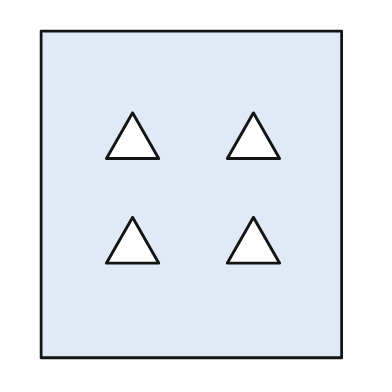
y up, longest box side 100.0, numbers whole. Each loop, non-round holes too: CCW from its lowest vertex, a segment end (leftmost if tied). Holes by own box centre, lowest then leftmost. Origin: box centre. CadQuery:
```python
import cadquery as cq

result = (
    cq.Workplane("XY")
    .moveTo(-46.0, -50.0)
    .lineTo(46.0, -50.0)
    .lineTo(46.0, 50.0)
    .lineTo(-46.0, 50.0)
    .close()
    .moveTo(-26.0, -21.0)
    .lineTo(-10.0, -21.0)
    .lineTo(-18.0, -7.0)
    .close()
    .moveTo(11.0, -21.0)
    .lineTo(27.0, -21.0)
    .lineTo(19.0, -7.0)
    .close()
    .moveTo(-26.0, 11.0)
    .lineTo(-10.0, 11.0)
    .lineTo(-18.0, 25.0)
    .close()
    .moveTo(11.0, 11.0)
    .lineTo(27.0, 11.0)
    .lineTo(19.0, 25.0)
    .close()
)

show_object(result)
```